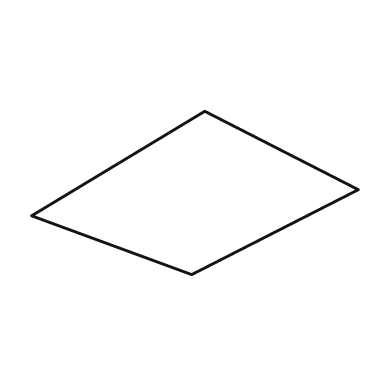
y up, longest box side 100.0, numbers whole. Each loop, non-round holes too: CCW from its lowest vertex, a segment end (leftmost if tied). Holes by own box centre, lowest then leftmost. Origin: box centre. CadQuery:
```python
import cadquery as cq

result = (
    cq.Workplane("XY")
    .moveTo(-1.0, -25.0)
    .lineTo(50.0, 1.0)
    .lineTo(3.0, 25.0)
    .lineTo(-50.0, -7.0)
    .close()
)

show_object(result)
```